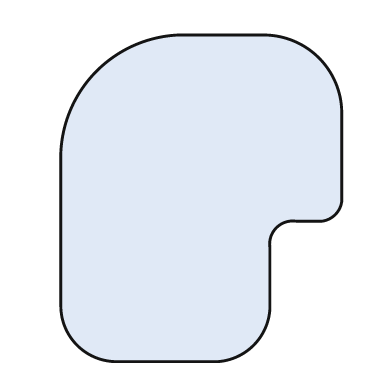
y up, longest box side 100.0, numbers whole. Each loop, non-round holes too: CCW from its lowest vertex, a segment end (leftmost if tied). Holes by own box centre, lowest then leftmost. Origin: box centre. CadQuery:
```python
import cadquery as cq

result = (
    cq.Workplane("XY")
    .moveTo(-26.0, -50.0)
    .lineTo(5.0, -50.0)
    .threePointArc((16.0, -45.0), (21.0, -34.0))
    .lineTo(21.0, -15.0)
    .threePointArc((23.0, -9.0), (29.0, -7.0))
    .lineTo(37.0, -7.0)
    .threePointArc((41.0, -5.0), (43.0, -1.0))
    .lineTo(43.0, 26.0)
    .threePointArc((36.0, 43.0), (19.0, 50.0))
    .lineTo(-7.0, 50.0)
    .threePointArc((-32.0, 39.0), (-43.0, 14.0))
    .lineTo(-43.0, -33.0)
    .threePointArc((-38.0, -45.0), (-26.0, -50.0))
    .close()
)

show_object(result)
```